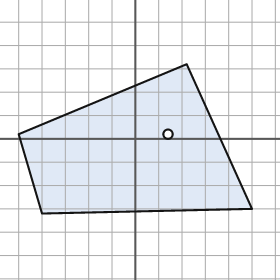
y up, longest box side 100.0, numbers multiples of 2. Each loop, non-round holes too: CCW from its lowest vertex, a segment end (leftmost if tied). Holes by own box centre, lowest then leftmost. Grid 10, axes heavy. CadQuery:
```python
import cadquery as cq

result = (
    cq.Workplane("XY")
    .moveTo(-40.0, -32.0)
    .lineTo(50.0, -30.0)
    .lineTo(22.0, 32.0)
    .lineTo(-50.0, 2.0)
    .close()
    .moveTo(14.0, 2.0)
    .circle(2.0)
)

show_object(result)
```